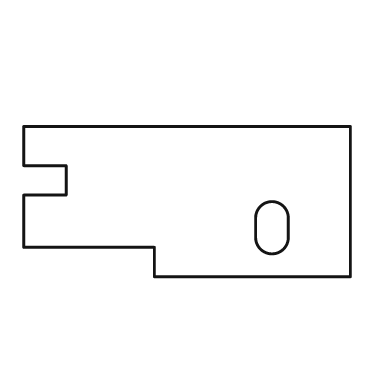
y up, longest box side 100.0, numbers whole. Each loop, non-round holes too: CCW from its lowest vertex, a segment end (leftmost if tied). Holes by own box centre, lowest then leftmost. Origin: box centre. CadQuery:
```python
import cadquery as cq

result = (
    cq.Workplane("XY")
    .moveTo(-10.0, -23.0)
    .lineTo(50.0, -23.0)
    .lineTo(50.0, 23.0)
    .lineTo(-50.0, 23.0)
    .lineTo(-50.0, 11.0)
    .lineTo(-37.0, 11.0)
    .lineTo(-37.0, 2.0)
    .lineTo(-50.0, 2.0)
    .lineTo(-50.0, -14.0)
    .lineTo(-10.0, -14.0)
    .close()
    .moveTo(21.0, -11.0)
    .threePointArc((26.0, -16.0), (31.0, -11.0))
    .lineTo(31.0, -5.0)
    .threePointArc((26.0, 0.0), (21.0, -5.0))
    .close()
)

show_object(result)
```